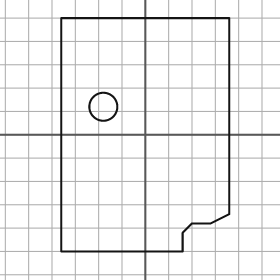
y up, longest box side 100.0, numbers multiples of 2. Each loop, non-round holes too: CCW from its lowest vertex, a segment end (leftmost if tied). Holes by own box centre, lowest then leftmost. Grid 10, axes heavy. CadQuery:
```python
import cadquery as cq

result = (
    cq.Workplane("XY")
    .moveTo(-36.0, -50.0)
    .lineTo(16.0, -50.0)
    .lineTo(16.0, -42.0)
    .lineTo(20.0, -38.0)
    .lineTo(28.0, -38.0)
    .lineTo(36.0, -34.0)
    .lineTo(36.0, 50.0)
    .lineTo(-36.0, 50.0)
    .close()
    .moveTo(-18.0, 12.0)
    .circle(6.0)
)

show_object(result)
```